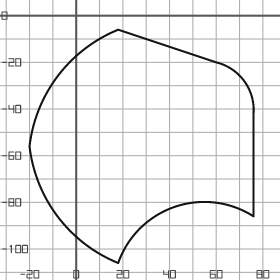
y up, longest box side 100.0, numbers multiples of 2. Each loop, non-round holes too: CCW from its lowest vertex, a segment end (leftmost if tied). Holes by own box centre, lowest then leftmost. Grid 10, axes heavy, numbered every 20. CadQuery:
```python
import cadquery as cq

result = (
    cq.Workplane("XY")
    .moveTo(18.0, -106.0)
    .threePointArc((42.0, -82.0), (76.0, -86.0))
    .lineTo(76.0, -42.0)
    .threePointArc((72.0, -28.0), (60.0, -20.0))
    .lineTo(18.0, -6.0)
    .threePointArc((-8.0, -26.0), (-20.0, -56.0))
    .threePointArc((-8.0, -86.0), (18.0, -106.0))
    .close()
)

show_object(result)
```